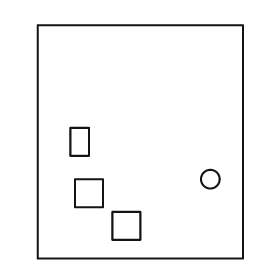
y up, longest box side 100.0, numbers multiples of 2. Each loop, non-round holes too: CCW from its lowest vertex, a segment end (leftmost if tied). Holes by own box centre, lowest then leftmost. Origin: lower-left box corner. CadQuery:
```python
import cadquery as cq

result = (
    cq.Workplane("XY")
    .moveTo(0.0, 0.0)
    .lineTo(88.0, 0.0)
    .lineTo(88.0, 100.0)
    .lineTo(0.0, 100.0)
    .close()
    .moveTo(32.0, 8.0)
    .lineTo(44.0, 8.0)
    .lineTo(44.0, 20.0)
    .lineTo(32.0, 20.0)
    .close()
    .moveTo(16.0, 22.0)
    .lineTo(28.0, 22.0)
    .lineTo(28.0, 34.0)
    .lineTo(16.0, 34.0)
    .close()
    .moveTo(74.0, 34.0)
    .circle(4.0)
    .moveTo(14.0, 44.0)
    .lineTo(22.0, 44.0)
    .lineTo(22.0, 56.0)
    .lineTo(14.0, 56.0)
    .close()
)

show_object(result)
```